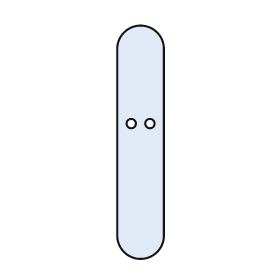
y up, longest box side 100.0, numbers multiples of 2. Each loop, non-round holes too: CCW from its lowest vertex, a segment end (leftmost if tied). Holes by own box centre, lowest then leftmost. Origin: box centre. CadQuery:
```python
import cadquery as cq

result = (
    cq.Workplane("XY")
    .moveTo(-10.0, -40.0)
    .threePointArc((0.0, -50.0), (10.0, -40.0))
    .lineTo(10.0, 40.0)
    .threePointArc((0.0, 50.0), (-10.0, 40.0))
    .close()
    .moveTo(-4.0, 8.0)
    .circle(2.0)
    .moveTo(4.0, 8.0)
    .circle(2.0)
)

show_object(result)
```